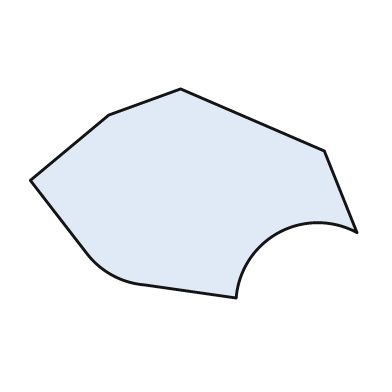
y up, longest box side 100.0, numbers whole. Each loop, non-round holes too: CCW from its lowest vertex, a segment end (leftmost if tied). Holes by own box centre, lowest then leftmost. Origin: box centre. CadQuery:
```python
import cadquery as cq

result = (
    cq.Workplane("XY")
    .moveTo(13.0, -32.0)
    .threePointArc((26.0, -12.0), (50.0, -12.0))
    .lineTo(40.0, 13.0)
    .lineTo(-4.0, 32.0)
    .lineTo(-26.0, 24.0)
    .lineTo(-50.0, 4.0)
    .lineTo(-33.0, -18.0)
    .threePointArc((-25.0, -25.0), (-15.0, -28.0))
    .close()
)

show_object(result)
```